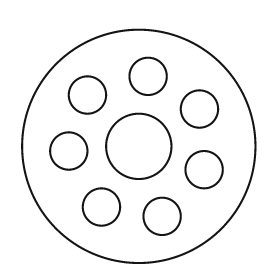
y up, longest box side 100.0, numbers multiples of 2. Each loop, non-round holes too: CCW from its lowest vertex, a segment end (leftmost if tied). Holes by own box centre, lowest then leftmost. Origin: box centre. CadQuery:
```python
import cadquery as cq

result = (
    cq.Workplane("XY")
    .moveTo(0.0, 0.0)
    .circle(50.0)
    .moveTo(10.0, -30.0)
    .circle(8.0)
    .moveTo(-16.0, -26.0)
    .circle(8.0)
    .moveTo(28.0, -10.0)
    .circle(8.0)
    .moveTo(-30.0, -2.0)
    .circle(8.0)
    .moveTo(0.0, 0.0)
    .circle(14.0)
    .moveTo(26.0, 16.0)
    .circle(8.0)
    .moveTo(-22.0, 22.0)
    .circle(8.0)
    .moveTo(4.0, 30.0)
    .circle(8.0)
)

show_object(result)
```